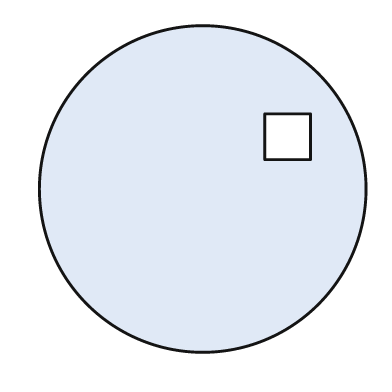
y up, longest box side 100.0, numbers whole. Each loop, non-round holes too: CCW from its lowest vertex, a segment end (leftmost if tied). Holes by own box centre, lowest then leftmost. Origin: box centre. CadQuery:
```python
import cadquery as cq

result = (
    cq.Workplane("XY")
    .moveTo(0.0, 0.0)
    .circle(50.0)
    .moveTo(19.0, 9.0)
    .lineTo(33.0, 9.0)
    .lineTo(33.0, 23.0)
    .lineTo(19.0, 23.0)
    .close()
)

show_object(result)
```